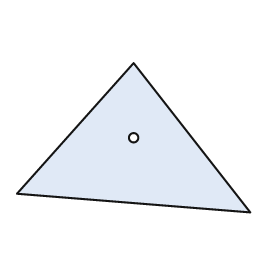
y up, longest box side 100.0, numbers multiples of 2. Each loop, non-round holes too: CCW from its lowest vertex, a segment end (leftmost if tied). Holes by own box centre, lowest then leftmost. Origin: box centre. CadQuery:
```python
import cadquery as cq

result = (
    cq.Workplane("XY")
    .moveTo(50.0, -32.0)
    .lineTo(0.0, 32.0)
    .lineTo(-50.0, -24.0)
    .close()
    .moveTo(0.0, 0.0)
    .circle(2.0)
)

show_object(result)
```